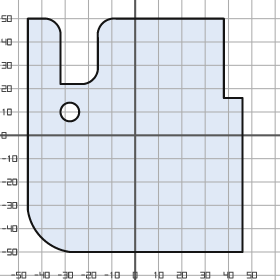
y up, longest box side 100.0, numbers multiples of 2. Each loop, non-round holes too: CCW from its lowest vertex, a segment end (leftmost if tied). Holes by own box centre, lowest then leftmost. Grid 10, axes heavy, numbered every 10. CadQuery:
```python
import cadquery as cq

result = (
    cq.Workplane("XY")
    .moveTo(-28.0, -50.0)
    .lineTo(46.0, -50.0)
    .lineTo(46.0, 16.0)
    .lineTo(38.0, 16.0)
    .lineTo(38.0, 50.0)
    .lineTo(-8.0, 50.0)
    .threePointArc((-14.0, 48.0), (-16.0, 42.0))
    .lineTo(-16.0, 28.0)
    .threePointArc((-18.0, 24.0), (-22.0, 22.0))
    .lineTo(-32.0, 22.0)
    .lineTo(-32.0, 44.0)
    .threePointArc((-34.0, 48.0), (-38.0, 50.0))
    .lineTo(-46.0, 50.0)
    .lineTo(-46.0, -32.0)
    .threePointArc((-40.0, -44.0), (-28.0, -50.0))
    .close()
    .moveTo(-28.0, 10.0)
    .circle(4.0)
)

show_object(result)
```